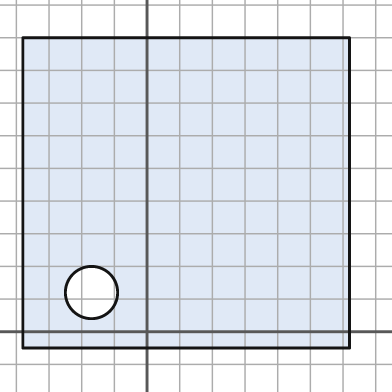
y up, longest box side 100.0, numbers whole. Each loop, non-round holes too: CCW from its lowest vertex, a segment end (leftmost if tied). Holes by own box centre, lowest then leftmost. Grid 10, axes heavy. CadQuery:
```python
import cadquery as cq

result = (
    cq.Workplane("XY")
    .moveTo(-38.0, -5.0)
    .lineTo(62.0, -5.0)
    .lineTo(62.0, 90.0)
    .lineTo(-38.0, 90.0)
    .close()
    .moveTo(-17.0, 12.0)
    .circle(8.0)
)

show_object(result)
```